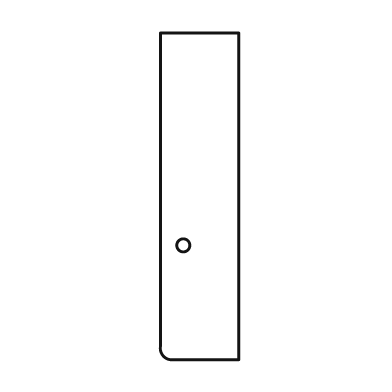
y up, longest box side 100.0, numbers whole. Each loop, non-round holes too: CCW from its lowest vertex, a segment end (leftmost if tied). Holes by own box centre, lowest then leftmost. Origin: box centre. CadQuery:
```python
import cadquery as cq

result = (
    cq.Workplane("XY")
    .moveTo(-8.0, -50.0)
    .lineTo(12.0, -50.0)
    .lineTo(12.0, 50.0)
    .lineTo(-12.0, 50.0)
    .lineTo(-12.0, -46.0)
    .threePointArc((-11.0, -49.0), (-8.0, -50.0))
    .close()
    .moveTo(-5.0, -15.0)
    .circle(2.0)
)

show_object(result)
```